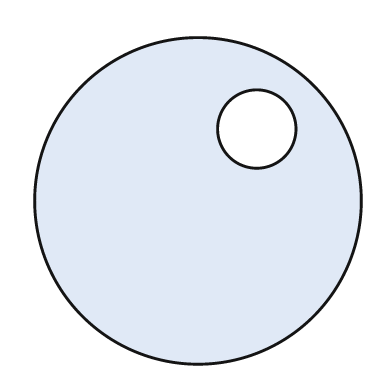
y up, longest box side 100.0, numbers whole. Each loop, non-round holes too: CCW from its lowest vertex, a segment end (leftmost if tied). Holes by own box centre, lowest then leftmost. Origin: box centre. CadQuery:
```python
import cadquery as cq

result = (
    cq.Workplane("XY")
    .moveTo(0.0, 0.0)
    .circle(50.0)
    .moveTo(18.0, 22.0)
    .circle(12.0)
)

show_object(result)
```